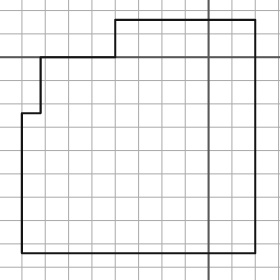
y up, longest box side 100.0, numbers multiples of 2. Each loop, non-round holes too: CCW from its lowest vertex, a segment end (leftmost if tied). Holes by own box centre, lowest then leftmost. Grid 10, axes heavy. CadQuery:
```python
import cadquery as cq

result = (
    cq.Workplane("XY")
    .moveTo(-80.0, -84.0)
    .lineTo(20.0, -84.0)
    .lineTo(20.0, 16.0)
    .lineTo(-40.0, 16.0)
    .lineTo(-40.0, 0.0)
    .lineTo(-72.0, 0.0)
    .lineTo(-72.0, -24.0)
    .lineTo(-80.0, -24.0)
    .close()
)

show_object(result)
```